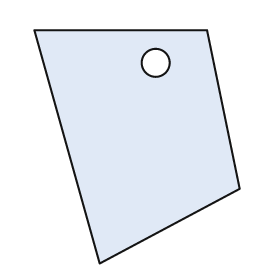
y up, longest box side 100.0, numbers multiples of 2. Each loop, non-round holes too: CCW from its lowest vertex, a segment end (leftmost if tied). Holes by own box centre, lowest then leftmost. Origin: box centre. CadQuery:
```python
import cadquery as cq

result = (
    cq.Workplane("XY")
    .moveTo(-16.0, -50.0)
    .lineTo(44.0, -18.0)
    .lineTo(30.0, 50.0)
    .lineTo(-44.0, 50.0)
    .close()
    .moveTo(8.0, 36.0)
    .circle(6.0)
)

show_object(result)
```